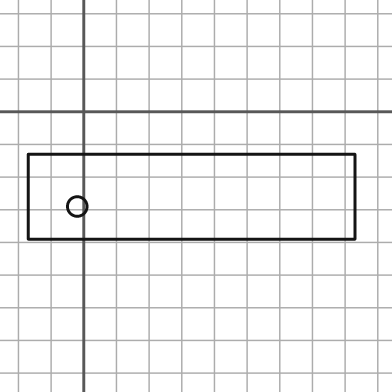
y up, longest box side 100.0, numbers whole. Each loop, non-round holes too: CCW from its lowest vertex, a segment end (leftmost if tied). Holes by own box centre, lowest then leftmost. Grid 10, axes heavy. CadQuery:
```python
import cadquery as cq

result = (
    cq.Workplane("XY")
    .moveTo(-17.0, -39.0)
    .lineTo(83.0, -39.0)
    .lineTo(83.0, -13.0)
    .lineTo(-17.0, -13.0)
    .close()
    .moveTo(-2.0, -29.0)
    .circle(3.0)
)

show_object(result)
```